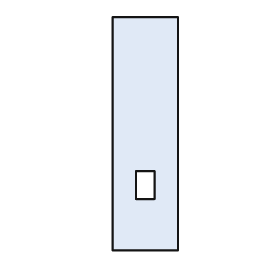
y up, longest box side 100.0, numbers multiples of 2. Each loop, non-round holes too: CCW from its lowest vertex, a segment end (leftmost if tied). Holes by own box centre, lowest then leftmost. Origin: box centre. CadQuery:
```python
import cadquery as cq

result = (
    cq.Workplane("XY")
    .moveTo(-14.0, -50.0)
    .lineTo(14.0, -50.0)
    .lineTo(14.0, 50.0)
    .lineTo(-14.0, 50.0)
    .close()
    .moveTo(-4.0, -28.0)
    .lineTo(4.0, -28.0)
    .lineTo(4.0, -16.0)
    .lineTo(-4.0, -16.0)
    .close()
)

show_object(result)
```